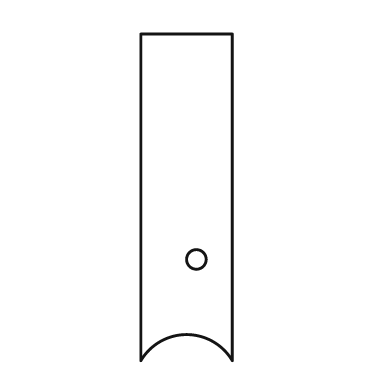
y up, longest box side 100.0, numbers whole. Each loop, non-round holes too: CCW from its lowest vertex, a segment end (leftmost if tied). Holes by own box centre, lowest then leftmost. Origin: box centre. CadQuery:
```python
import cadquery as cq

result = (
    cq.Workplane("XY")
    .moveTo(-14.0, -50.0)
    .threePointArc((0.0, -42.0), (14.0, -50.0))
    .lineTo(14.0, 50.0)
    .lineTo(-14.0, 50.0)
    .close()
    .moveTo(3.0, -19.0)
    .circle(3.0)
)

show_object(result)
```